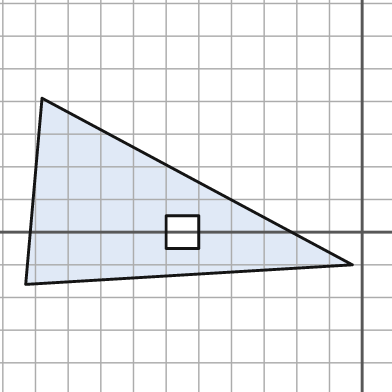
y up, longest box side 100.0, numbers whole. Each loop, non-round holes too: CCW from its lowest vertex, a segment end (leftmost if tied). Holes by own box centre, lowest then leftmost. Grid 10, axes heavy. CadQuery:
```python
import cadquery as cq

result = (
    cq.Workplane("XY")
    .moveTo(-103.0, -16.0)
    .lineTo(-3.0, -10.0)
    .lineTo(-98.0, 41.0)
    .close()
    .moveTo(-60.0, -5.0)
    .lineTo(-50.0, -5.0)
    .lineTo(-50.0, 5.0)
    .lineTo(-60.0, 5.0)
    .close()
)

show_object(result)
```